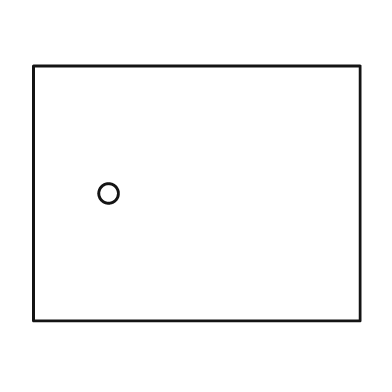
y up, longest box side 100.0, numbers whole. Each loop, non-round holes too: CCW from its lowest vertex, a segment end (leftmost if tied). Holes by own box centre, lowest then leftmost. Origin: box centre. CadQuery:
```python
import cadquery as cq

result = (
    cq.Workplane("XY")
    .moveTo(-50.0, -39.0)
    .lineTo(50.0, -39.0)
    .lineTo(50.0, 39.0)
    .lineTo(-50.0, 39.0)
    .close()
    .moveTo(-27.0, 0.0)
    .circle(3.0)
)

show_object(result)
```